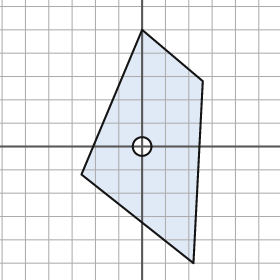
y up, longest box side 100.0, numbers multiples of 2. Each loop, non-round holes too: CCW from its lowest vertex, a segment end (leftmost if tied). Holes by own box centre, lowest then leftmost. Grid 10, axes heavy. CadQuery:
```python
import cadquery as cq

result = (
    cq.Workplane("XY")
    .moveTo(22.0, -50.0)
    .lineTo(26.0, 28.0)
    .lineTo(0.0, 50.0)
    .lineTo(-26.0, -12.0)
    .close()
    .moveTo(0.0, 0.0)
    .circle(4.0)
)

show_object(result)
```